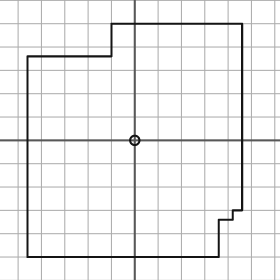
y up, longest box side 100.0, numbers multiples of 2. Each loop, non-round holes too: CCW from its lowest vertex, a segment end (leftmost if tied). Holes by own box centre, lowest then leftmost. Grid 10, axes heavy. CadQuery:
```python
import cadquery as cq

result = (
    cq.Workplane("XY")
    .moveTo(-46.0, -50.0)
    .lineTo(36.0, -50.0)
    .lineTo(36.0, -34.0)
    .lineTo(42.0, -34.0)
    .lineTo(42.0, -30.0)
    .lineTo(46.0, -30.0)
    .lineTo(46.0, 50.0)
    .lineTo(-10.0, 50.0)
    .lineTo(-10.0, 36.0)
    .lineTo(-46.0, 36.0)
    .close()
    .moveTo(0.0, 0.0)
    .circle(2.0)
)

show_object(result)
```